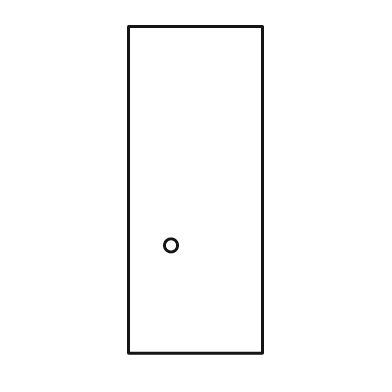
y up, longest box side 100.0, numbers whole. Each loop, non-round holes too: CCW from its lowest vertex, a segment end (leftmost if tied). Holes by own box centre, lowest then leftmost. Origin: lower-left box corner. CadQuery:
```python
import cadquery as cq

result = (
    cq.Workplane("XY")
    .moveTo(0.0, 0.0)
    .lineTo(41.0, 0.0)
    .lineTo(41.0, 100.0)
    .lineTo(0.0, 100.0)
    .close()
    .moveTo(13.0, 33.0)
    .circle(2.0)
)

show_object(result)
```